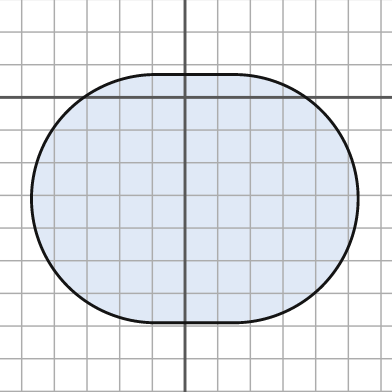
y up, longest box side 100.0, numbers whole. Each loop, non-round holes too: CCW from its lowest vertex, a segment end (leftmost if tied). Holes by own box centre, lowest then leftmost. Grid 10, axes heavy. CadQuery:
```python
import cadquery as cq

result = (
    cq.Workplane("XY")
    .moveTo(-9.0, -69.0)
    .lineTo(15.0, -69.0)
    .threePointArc((53.0, -31.0), (15.0, 7.0))
    .lineTo(-9.0, 7.0)
    .threePointArc((-47.0, -31.0), (-9.0, -69.0))
    .close()
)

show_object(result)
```